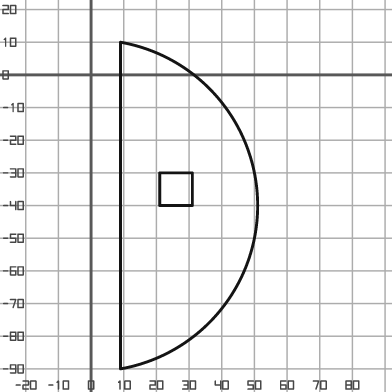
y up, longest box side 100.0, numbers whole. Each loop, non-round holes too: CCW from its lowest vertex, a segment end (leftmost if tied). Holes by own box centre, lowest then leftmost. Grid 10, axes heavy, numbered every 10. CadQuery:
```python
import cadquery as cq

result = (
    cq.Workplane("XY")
    .moveTo(9.0, -90.0)
    .threePointArc((51.0, -40.0), (9.0, 10.0))
    .close()
    .moveTo(21.0, -40.0)
    .lineTo(31.0, -40.0)
    .lineTo(31.0, -30.0)
    .lineTo(21.0, -30.0)
    .close()
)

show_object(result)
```